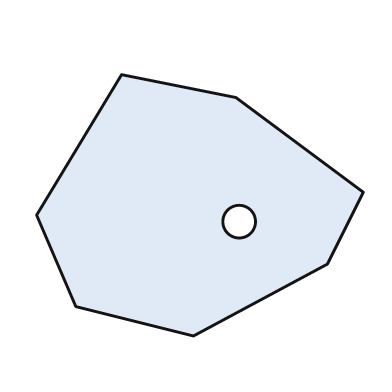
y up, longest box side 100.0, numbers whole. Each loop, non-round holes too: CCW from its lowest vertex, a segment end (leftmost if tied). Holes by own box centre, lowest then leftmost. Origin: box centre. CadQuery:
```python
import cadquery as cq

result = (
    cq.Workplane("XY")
    .moveTo(-2.0, -40.0)
    .lineTo(39.0, -18.0)
    .lineTo(50.0, 4.0)
    .lineTo(11.0, 33.0)
    .lineTo(-24.0, 40.0)
    .lineTo(-50.0, -3.0)
    .lineTo(-38.0, -31.0)
    .close()
    .moveTo(12.0, -5.0)
    .circle(5.0)
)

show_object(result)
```